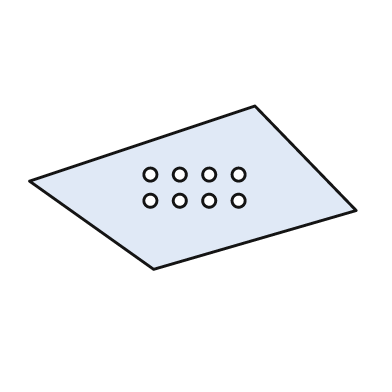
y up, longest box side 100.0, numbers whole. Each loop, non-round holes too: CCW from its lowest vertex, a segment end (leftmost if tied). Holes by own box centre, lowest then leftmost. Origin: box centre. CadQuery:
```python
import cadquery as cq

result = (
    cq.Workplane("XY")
    .moveTo(-12.0, -25.0)
    .lineTo(50.0, -7.0)
    .lineTo(19.0, 25.0)
    .lineTo(-50.0, 2.0)
    .close()
    .moveTo(-13.0, -4.0)
    .circle(2.0)
    .moveTo(-4.0, -4.0)
    .circle(2.0)
    .moveTo(5.0, -4.0)
    .circle(2.0)
    .moveTo(14.0, -4.0)
    .circle(2.0)
    .moveTo(-13.0, 4.0)
    .circle(2.0)
    .moveTo(-4.0, 4.0)
    .circle(2.0)
    .moveTo(5.0, 4.0)
    .circle(2.0)
    .moveTo(14.0, 4.0)
    .circle(2.0)
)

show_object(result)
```